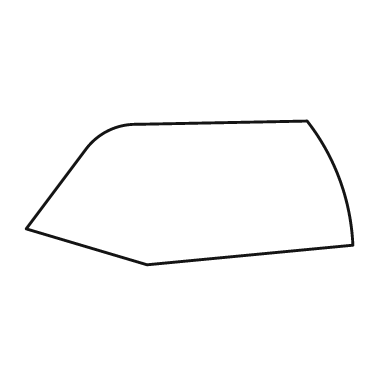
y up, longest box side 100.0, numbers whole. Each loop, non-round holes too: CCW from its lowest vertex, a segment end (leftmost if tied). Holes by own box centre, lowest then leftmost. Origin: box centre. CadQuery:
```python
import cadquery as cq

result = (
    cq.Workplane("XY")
    .moveTo(-13.0, -22.0)
    .lineTo(50.0, -16.0)
    .threePointArc((46.0, 4.0), (36.0, 22.0))
    .lineTo(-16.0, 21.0)
    .threePointArc((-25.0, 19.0), (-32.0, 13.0))
    .lineTo(-50.0, -11.0)
    .close()
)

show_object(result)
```